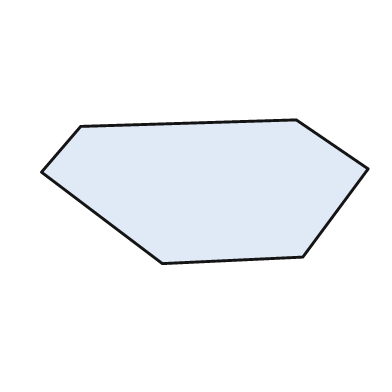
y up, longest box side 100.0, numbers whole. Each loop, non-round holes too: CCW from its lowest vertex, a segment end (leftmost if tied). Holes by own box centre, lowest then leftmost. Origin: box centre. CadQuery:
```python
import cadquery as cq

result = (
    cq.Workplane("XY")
    .moveTo(-13.0, -22.0)
    .lineTo(30.0, -20.0)
    .lineTo(50.0, 7.0)
    .lineTo(28.0, 22.0)
    .lineTo(-38.0, 20.0)
    .lineTo(-50.0, 6.0)
    .close()
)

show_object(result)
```